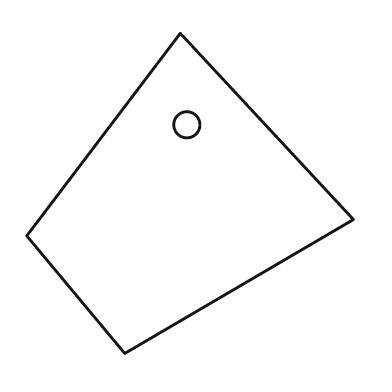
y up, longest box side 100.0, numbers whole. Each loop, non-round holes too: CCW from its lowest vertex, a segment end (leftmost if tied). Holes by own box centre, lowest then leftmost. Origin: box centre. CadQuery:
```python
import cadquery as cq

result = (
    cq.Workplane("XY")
    .moveTo(-20.0, -49.0)
    .lineTo(50.0, -8.0)
    .lineTo(-3.0, 49.0)
    .lineTo(-50.0, -13.0)
    .close()
    .moveTo(-1.0, 21.0)
    .circle(4.0)
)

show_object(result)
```